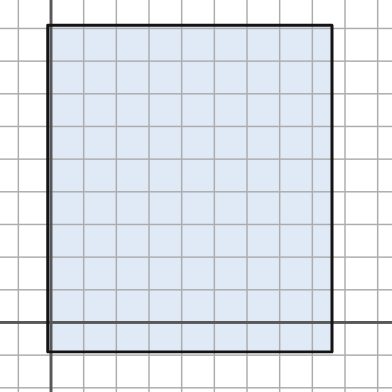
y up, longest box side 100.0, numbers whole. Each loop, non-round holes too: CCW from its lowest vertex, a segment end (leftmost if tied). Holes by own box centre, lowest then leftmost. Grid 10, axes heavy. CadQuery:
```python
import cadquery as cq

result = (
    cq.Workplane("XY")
    .moveTo(-1.0, -9.0)
    .lineTo(86.0, -9.0)
    .lineTo(86.0, 91.0)
    .lineTo(-1.0, 91.0)
    .close()
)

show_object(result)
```